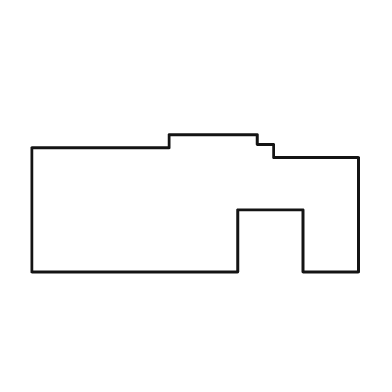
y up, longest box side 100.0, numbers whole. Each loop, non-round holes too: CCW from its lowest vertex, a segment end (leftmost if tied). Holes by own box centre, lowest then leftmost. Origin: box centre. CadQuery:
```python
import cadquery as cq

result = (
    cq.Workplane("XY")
    .moveTo(-50.0, -21.0)
    .lineTo(13.0, -21.0)
    .lineTo(13.0, -2.0)
    .lineTo(33.0, -2.0)
    .lineTo(33.0, -21.0)
    .lineTo(50.0, -21.0)
    .lineTo(50.0, 14.0)
    .lineTo(24.0, 14.0)
    .lineTo(24.0, 18.0)
    .lineTo(19.0, 18.0)
    .lineTo(19.0, 21.0)
    .lineTo(-8.0, 21.0)
    .lineTo(-8.0, 17.0)
    .lineTo(-50.0, 17.0)
    .close()
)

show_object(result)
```